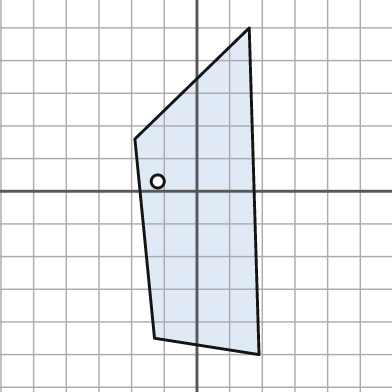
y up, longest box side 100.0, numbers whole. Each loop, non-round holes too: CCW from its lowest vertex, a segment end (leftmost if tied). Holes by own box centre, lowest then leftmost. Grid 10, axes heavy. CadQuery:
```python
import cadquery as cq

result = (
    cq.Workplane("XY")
    .moveTo(19.0, -50.0)
    .lineTo(16.0, 50.0)
    .lineTo(-19.0, 16.0)
    .lineTo(-13.0, -45.0)
    .close()
    .moveTo(-12.0, 3.0)
    .circle(2.0)
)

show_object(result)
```